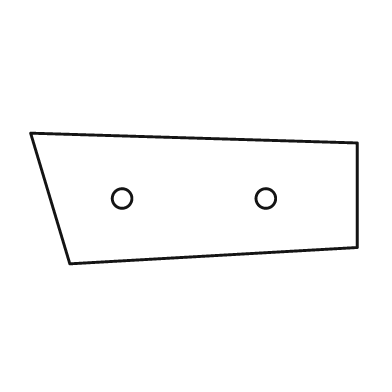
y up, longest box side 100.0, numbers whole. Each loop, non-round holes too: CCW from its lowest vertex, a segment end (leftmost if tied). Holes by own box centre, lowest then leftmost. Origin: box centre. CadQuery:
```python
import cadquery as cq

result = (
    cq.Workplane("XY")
    .moveTo(-38.0, -20.0)
    .lineTo(50.0, -15.0)
    .lineTo(50.0, 17.0)
    .lineTo(-50.0, 20.0)
    .close()
    .moveTo(-22.0, 0.0)
    .circle(3.0)
    .moveTo(22.0, 0.0)
    .circle(3.0)
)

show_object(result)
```